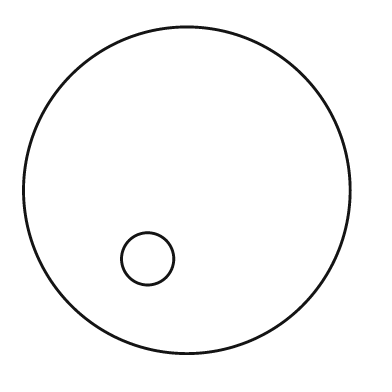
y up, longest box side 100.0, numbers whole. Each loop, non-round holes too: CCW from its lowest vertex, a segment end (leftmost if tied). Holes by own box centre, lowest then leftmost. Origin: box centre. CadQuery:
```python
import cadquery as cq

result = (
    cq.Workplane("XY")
    .moveTo(0.0, 0.0)
    .circle(50.0)
    .moveTo(-12.0, -21.0)
    .circle(8.0)
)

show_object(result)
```